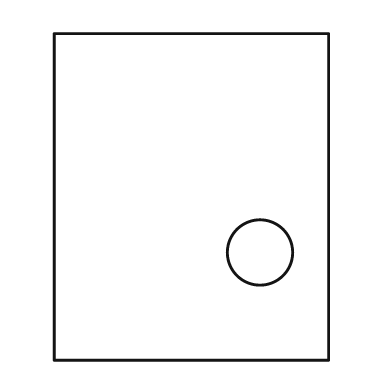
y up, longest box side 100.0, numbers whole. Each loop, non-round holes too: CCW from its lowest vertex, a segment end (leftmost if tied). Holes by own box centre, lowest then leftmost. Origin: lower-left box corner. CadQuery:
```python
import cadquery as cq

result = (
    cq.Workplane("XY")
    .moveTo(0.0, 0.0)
    .lineTo(84.0, 0.0)
    .lineTo(84.0, 100.0)
    .lineTo(0.0, 100.0)
    .close()
    .moveTo(63.0, 33.0)
    .circle(10.0)
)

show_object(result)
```